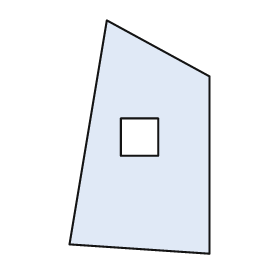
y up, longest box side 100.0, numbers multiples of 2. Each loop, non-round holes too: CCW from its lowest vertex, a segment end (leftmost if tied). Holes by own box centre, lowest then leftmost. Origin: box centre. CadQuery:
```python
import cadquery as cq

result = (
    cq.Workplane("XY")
    .moveTo(30.0, -50.0)
    .lineTo(30.0, 26.0)
    .lineTo(-14.0, 50.0)
    .lineTo(-30.0, -46.0)
    .close()
    .moveTo(-8.0, -8.0)
    .lineTo(8.0, -8.0)
    .lineTo(8.0, 8.0)
    .lineTo(-8.0, 8.0)
    .close()
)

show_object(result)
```